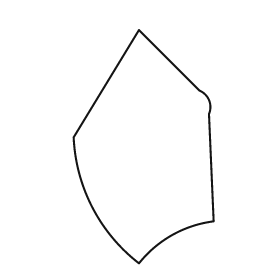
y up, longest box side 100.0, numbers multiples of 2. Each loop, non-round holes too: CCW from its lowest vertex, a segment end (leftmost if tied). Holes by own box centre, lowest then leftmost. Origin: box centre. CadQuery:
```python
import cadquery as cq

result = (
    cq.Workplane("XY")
    .moveTo(-2.0, -50.0)
    .threePointArc((12.0, -38.0), (30.0, -32.0))
    .lineTo(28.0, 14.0)
    .threePointArc((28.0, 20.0), (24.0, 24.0))
    .lineTo(-2.0, 50.0)
    .lineTo(-30.0, 4.0)
    .threePointArc((-22.0, -26.0), (-2.0, -50.0))
    .close()
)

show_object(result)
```